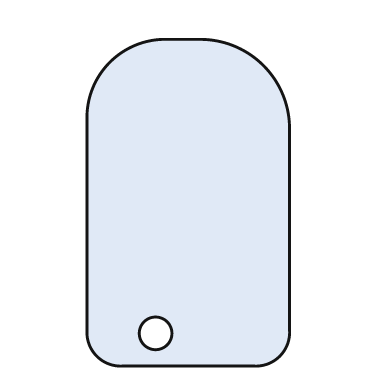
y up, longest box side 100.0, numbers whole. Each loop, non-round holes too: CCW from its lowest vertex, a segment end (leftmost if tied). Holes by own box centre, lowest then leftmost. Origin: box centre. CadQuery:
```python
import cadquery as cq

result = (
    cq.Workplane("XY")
    .moveTo(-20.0, -50.0)
    .lineTo(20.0, -50.0)
    .threePointArc((28.0, -47.0), (31.0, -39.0))
    .lineTo(31.0, 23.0)
    .threePointArc((23.0, 42.0), (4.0, 50.0))
    .lineTo(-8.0, 50.0)
    .threePointArc((-24.0, 43.0), (-31.0, 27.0))
    .lineTo(-31.0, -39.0)
    .threePointArc((-28.0, -47.0), (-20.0, -50.0))
    .close()
    .moveTo(-10.0, -40.0)
    .circle(5.0)
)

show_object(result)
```